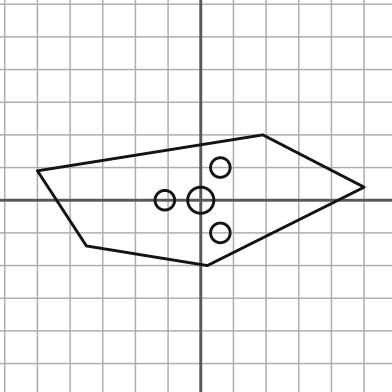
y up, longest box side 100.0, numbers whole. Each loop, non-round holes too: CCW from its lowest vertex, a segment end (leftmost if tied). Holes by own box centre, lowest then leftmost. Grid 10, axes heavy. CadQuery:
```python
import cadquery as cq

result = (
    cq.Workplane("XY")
    .moveTo(2.0, -20.0)
    .lineTo(50.0, 4.0)
    .lineTo(19.0, 20.0)
    .lineTo(-50.0, 9.0)
    .lineTo(-35.0, -14.0)
    .close()
    .moveTo(6.0, -10.0)
    .circle(3.0)
    .moveTo(-11.0, 0.0)
    .circle(3.0)
    .moveTo(0.0, 0.0)
    .circle(4.0)
    .moveTo(6.0, 10.0)
    .circle(3.0)
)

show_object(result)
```